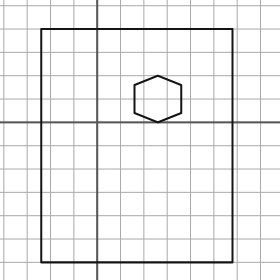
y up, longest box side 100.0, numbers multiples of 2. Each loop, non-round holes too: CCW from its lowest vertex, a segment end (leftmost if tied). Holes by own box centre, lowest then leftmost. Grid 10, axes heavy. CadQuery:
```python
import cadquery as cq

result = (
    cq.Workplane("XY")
    .moveTo(-24.0, -60.0)
    .lineTo(58.0, -60.0)
    .lineTo(58.0, 40.0)
    .lineTo(-24.0, 40.0)
    .close()
    .moveTo(26.0, 0.0)
    .lineTo(36.0, 4.0)
    .lineTo(36.0, 16.0)
    .lineTo(26.0, 20.0)
    .lineTo(16.0, 16.0)
    .lineTo(16.0, 4.0)
    .close()
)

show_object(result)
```